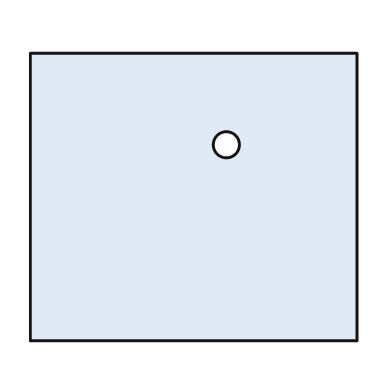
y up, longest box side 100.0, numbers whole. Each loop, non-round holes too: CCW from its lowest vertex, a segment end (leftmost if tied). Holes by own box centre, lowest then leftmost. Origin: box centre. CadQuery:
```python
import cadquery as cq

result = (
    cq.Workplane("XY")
    .moveTo(-50.0, -44.0)
    .lineTo(50.0, -44.0)
    .lineTo(50.0, 44.0)
    .lineTo(-50.0, 44.0)
    .close()
    .moveTo(10.0, 16.0)
    .circle(4.0)
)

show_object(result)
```